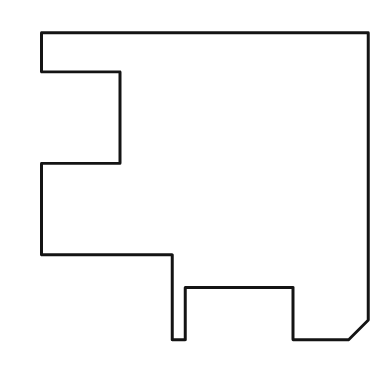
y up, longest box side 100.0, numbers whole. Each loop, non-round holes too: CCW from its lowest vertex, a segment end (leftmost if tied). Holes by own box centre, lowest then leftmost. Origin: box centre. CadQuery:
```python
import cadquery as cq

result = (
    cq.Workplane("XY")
    .moveTo(-10.0, -47.0)
    .lineTo(-6.0, -47.0)
    .lineTo(-6.0, -31.0)
    .lineTo(27.0, -31.0)
    .lineTo(27.0, -47.0)
    .lineTo(44.0, -47.0)
    .lineTo(50.0, -41.0)
    .lineTo(50.0, 47.0)
    .lineTo(-50.0, 47.0)
    .lineTo(-50.0, 35.0)
    .lineTo(-26.0, 35.0)
    .lineTo(-26.0, 7.0)
    .lineTo(-50.0, 7.0)
    .lineTo(-50.0, -21.0)
    .lineTo(-10.0, -21.0)
    .close()
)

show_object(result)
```